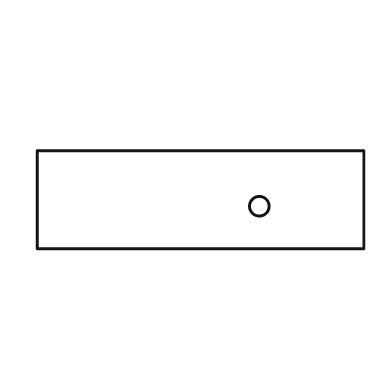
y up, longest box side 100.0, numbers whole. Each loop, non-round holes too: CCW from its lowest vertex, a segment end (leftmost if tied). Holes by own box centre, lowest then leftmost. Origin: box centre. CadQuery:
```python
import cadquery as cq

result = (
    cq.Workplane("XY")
    .moveTo(-50.0, -15.0)
    .lineTo(50.0, -15.0)
    .lineTo(50.0, 15.0)
    .lineTo(-50.0, 15.0)
    .close()
    .moveTo(18.0, -2.0)
    .circle(3.0)
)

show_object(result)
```